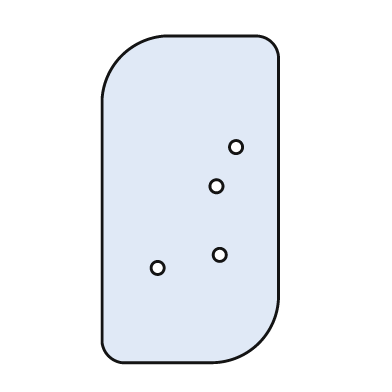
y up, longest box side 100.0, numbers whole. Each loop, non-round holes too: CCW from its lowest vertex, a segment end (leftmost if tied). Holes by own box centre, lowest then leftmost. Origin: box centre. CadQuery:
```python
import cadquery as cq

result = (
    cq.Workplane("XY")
    .moveTo(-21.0, -50.0)
    .lineTo(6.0, -50.0)
    .threePointArc((21.0, -44.0), (27.0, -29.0))
    .lineTo(27.0, 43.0)
    .threePointArc((25.0, 48.0), (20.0, 50.0))
    .lineTo(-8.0, 50.0)
    .threePointArc((-21.0, 44.0), (-27.0, 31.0))
    .lineTo(-27.0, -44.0)
    .threePointArc((-25.0, -48.0), (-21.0, -50.0))
    .close()
    .moveTo(-10.0, -21.0)
    .circle(2.0)
    .moveTo(9.0, -17.0)
    .circle(2.0)
    .moveTo(8.0, 4.0)
    .circle(2.0)
    .moveTo(14.0, 16.0)
    .circle(2.0)
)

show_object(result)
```